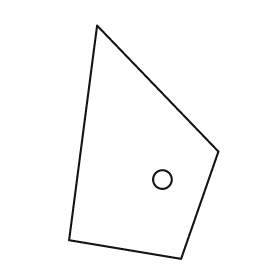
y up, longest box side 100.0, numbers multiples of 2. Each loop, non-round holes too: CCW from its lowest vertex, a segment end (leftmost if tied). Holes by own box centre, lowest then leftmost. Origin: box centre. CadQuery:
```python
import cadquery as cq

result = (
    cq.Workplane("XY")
    .moveTo(16.0, -50.0)
    .lineTo(32.0, -4.0)
    .lineTo(-20.0, 50.0)
    .lineTo(-32.0, -42.0)
    .close()
    .moveTo(8.0, -16.0)
    .circle(4.0)
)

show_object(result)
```